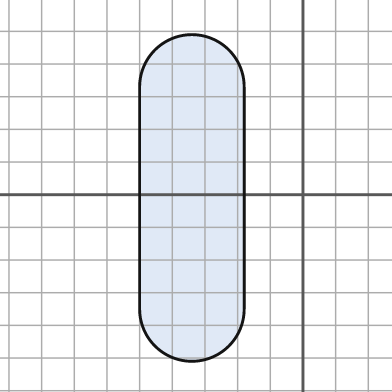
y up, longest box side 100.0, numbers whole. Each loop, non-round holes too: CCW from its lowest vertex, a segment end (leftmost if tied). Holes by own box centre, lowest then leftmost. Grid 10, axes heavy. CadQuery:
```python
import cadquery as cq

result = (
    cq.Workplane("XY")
    .moveTo(-50.0, -35.0)
    .threePointArc((-34.0, -51.0), (-18.0, -35.0))
    .lineTo(-18.0, 33.0)
    .threePointArc((-34.0, 49.0), (-50.0, 33.0))
    .close()
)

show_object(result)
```